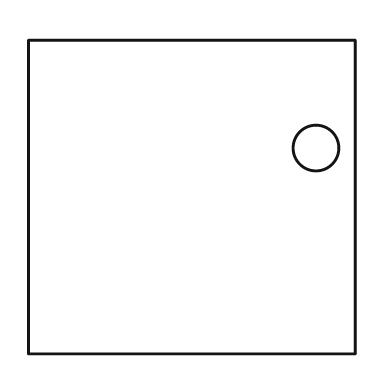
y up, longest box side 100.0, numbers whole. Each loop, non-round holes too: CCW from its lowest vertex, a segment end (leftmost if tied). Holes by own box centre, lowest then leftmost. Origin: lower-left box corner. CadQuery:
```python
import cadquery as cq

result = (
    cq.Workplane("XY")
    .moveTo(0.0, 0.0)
    .lineTo(100.0, 0.0)
    .lineTo(100.0, 96.0)
    .lineTo(0.0, 96.0)
    .close()
    .moveTo(88.0, 63.0)
    .circle(7.0)
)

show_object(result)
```